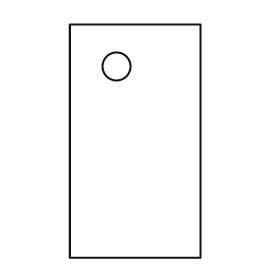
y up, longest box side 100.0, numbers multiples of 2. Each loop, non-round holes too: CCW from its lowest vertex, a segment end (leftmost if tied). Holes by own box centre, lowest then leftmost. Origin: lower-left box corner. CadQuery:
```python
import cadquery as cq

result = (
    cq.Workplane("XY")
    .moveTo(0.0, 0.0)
    .lineTo(56.0, 0.0)
    .lineTo(56.0, 100.0)
    .lineTo(0.0, 100.0)
    .close()
    .moveTo(20.0, 82.0)
    .circle(6.0)
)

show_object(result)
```